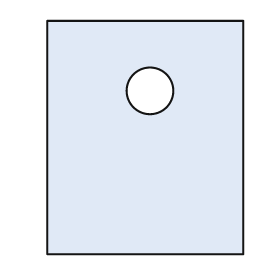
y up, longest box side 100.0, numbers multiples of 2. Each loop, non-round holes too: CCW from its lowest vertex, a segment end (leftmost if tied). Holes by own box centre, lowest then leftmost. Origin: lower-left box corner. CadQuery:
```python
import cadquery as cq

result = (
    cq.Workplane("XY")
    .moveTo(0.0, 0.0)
    .lineTo(84.0, 0.0)
    .lineTo(84.0, 100.0)
    .lineTo(0.0, 100.0)
    .close()
    .moveTo(44.0, 70.0)
    .circle(10.0)
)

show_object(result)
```